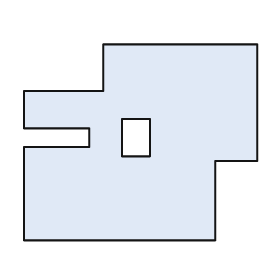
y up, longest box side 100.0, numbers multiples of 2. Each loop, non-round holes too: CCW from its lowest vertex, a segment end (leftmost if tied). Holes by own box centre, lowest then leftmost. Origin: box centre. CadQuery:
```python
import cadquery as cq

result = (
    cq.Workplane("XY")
    .moveTo(-50.0, -42.0)
    .lineTo(32.0, -42.0)
    .lineTo(32.0, -8.0)
    .lineTo(50.0, -8.0)
    .lineTo(50.0, 42.0)
    .lineTo(-16.0, 42.0)
    .lineTo(-16.0, 22.0)
    .lineTo(-50.0, 22.0)
    .lineTo(-50.0, 6.0)
    .lineTo(-22.0, 6.0)
    .lineTo(-22.0, -2.0)
    .lineTo(-50.0, -2.0)
    .close()
    .moveTo(-8.0, -6.0)
    .lineTo(4.0, -6.0)
    .lineTo(4.0, 10.0)
    .lineTo(-8.0, 10.0)
    .close()
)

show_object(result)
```